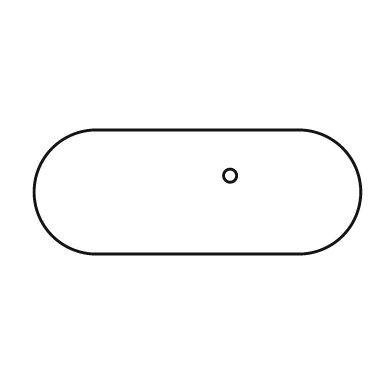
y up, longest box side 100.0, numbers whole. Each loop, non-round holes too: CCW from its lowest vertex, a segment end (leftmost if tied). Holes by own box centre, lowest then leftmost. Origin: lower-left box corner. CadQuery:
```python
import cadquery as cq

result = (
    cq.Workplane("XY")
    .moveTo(19.0, 0.0)
    .lineTo(81.0, 0.0)
    .threePointArc((100.0, 19.0), (81.0, 38.0))
    .lineTo(19.0, 38.0)
    .threePointArc((0.0, 19.0), (19.0, 0.0))
    .close()
    .moveTo(60.0, 24.0)
    .circle(2.0)
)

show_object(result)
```